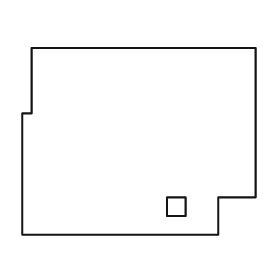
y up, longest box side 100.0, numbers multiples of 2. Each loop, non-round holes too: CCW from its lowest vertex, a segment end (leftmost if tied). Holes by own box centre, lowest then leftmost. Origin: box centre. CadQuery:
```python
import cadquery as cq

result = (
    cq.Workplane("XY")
    .moveTo(-50.0, -40.0)
    .lineTo(34.0, -40.0)
    .lineTo(34.0, -24.0)
    .lineTo(50.0, -24.0)
    .lineTo(50.0, 40.0)
    .lineTo(-46.0, 40.0)
    .lineTo(-46.0, 12.0)
    .lineTo(-50.0, 12.0)
    .close()
    .moveTo(12.0, -32.0)
    .lineTo(20.0, -32.0)
    .lineTo(20.0, -24.0)
    .lineTo(12.0, -24.0)
    .close()
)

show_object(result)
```